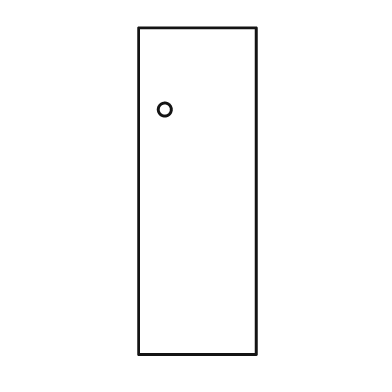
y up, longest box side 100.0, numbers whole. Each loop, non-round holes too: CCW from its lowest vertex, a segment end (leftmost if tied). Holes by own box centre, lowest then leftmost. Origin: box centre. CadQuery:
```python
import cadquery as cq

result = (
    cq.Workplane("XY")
    .moveTo(-18.0, -50.0)
    .lineTo(18.0, -50.0)
    .lineTo(18.0, 50.0)
    .lineTo(-18.0, 50.0)
    .close()
    .moveTo(-10.0, 25.0)
    .circle(2.0)
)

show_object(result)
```